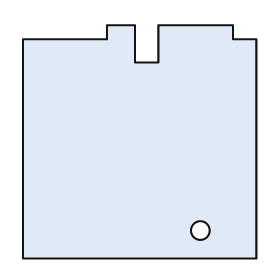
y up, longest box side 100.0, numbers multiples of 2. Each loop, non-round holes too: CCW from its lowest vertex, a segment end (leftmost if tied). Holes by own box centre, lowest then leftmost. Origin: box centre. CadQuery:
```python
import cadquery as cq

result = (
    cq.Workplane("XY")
    .moveTo(-50.0, -50.0)
    .lineTo(50.0, -50.0)
    .lineTo(50.0, 44.0)
    .lineTo(40.0, 44.0)
    .lineTo(40.0, 50.0)
    .lineTo(8.0, 50.0)
    .lineTo(8.0, 34.0)
    .lineTo(-2.0, 34.0)
    .lineTo(-2.0, 50.0)
    .lineTo(-14.0, 50.0)
    .lineTo(-14.0, 44.0)
    .lineTo(-50.0, 44.0)
    .close()
    .moveTo(26.0, -38.0)
    .circle(4.0)
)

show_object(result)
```